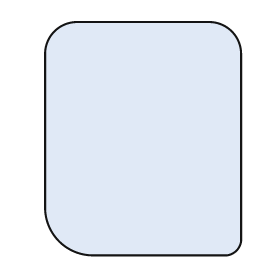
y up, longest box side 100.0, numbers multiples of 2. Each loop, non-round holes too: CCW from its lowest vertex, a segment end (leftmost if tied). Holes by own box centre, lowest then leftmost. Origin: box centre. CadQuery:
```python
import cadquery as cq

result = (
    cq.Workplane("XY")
    .moveTo(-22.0, -50.0)
    .lineTo(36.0, -50.0)
    .threePointArc((40.0, -48.0), (42.0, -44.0))
    .lineTo(42.0, 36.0)
    .threePointArc((38.0, 46.0), (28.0, 50.0))
    .lineTo(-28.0, 50.0)
    .threePointArc((-38.0, 46.0), (-42.0, 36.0))
    .lineTo(-42.0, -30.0)
    .threePointArc((-36.0, -44.0), (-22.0, -50.0))
    .close()
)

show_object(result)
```